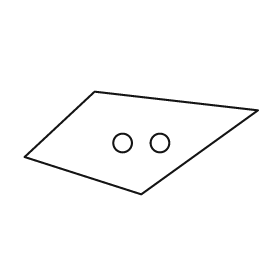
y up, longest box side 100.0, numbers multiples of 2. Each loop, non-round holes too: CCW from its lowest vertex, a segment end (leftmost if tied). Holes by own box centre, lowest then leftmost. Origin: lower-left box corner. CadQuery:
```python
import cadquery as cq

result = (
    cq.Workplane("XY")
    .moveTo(50.0, 0.0)
    .lineTo(100.0, 36.0)
    .lineTo(30.0, 44.0)
    .lineTo(0.0, 16.0)
    .close()
    .moveTo(42.0, 22.0)
    .circle(4.0)
    .moveTo(58.0, 22.0)
    .circle(4.0)
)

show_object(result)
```